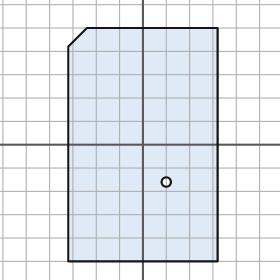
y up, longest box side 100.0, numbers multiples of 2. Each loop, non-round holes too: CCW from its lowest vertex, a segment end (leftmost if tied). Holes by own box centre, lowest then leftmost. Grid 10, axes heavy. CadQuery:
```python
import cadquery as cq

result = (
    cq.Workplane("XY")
    .moveTo(-32.0, -50.0)
    .lineTo(32.0, -50.0)
    .lineTo(32.0, 50.0)
    .lineTo(-24.0, 50.0)
    .lineTo(-32.0, 42.0)
    .close()
    .moveTo(10.0, -16.0)
    .circle(2.0)
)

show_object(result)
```